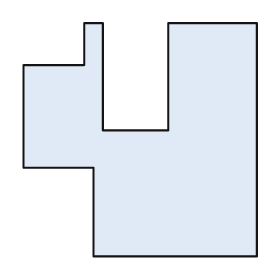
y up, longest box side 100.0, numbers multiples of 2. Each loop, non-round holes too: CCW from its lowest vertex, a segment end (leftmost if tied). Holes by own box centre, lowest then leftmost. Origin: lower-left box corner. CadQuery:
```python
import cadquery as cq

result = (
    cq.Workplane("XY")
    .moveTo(30.0, 0.0)
    .lineTo(100.0, 0.0)
    .lineTo(100.0, 100.0)
    .lineTo(62.0, 100.0)
    .lineTo(62.0, 54.0)
    .lineTo(34.0, 54.0)
    .lineTo(34.0, 100.0)
    .lineTo(26.0, 100.0)
    .lineTo(26.0, 82.0)
    .lineTo(0.0, 82.0)
    .lineTo(0.0, 38.0)
    .lineTo(30.0, 38.0)
    .close()
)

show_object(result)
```